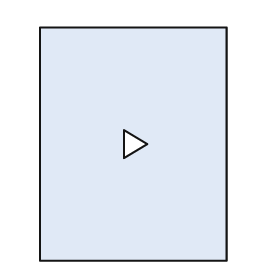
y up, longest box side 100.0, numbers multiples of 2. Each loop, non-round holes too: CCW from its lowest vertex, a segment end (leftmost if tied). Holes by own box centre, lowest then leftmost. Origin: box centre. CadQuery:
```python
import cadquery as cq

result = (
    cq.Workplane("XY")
    .moveTo(-40.0, -50.0)
    .lineTo(40.0, -50.0)
    .lineTo(40.0, 50.0)
    .lineTo(-40.0, 50.0)
    .close()
    .moveTo(-4.0, -6.0)
    .lineTo(6.0, 0.0)
    .lineTo(-4.0, 6.0)
    .close()
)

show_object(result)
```